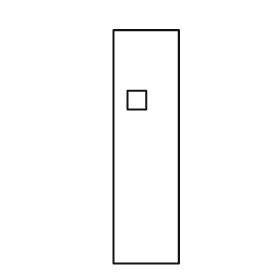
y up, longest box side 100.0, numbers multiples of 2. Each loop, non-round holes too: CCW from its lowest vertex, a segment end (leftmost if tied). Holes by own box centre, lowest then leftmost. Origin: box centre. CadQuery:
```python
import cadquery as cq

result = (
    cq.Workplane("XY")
    .moveTo(-14.0, -50.0)
    .lineTo(14.0, -50.0)
    .lineTo(14.0, 50.0)
    .lineTo(-14.0, 50.0)
    .close()
    .moveTo(-8.0, 16.0)
    .lineTo(0.0, 16.0)
    .lineTo(0.0, 24.0)
    .lineTo(-8.0, 24.0)
    .close()
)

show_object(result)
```